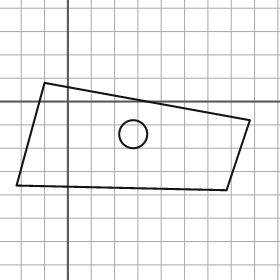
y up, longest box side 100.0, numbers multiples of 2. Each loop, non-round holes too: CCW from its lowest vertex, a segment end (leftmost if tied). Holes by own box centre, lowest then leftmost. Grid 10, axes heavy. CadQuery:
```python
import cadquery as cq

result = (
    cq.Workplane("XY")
    .moveTo(68.0, -38.0)
    .lineTo(78.0, -8.0)
    .lineTo(-10.0, 8.0)
    .lineTo(-22.0, -36.0)
    .close()
    .moveTo(28.0, -14.0)
    .circle(6.0)
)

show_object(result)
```